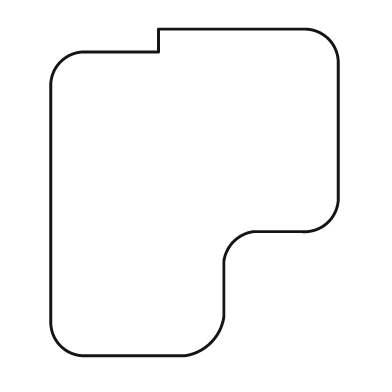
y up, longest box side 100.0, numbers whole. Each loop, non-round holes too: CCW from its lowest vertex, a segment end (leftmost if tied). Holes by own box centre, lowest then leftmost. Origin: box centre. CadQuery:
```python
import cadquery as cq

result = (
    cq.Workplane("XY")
    .moveTo(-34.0, -50.0)
    .lineTo(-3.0, -50.0)
    .threePointArc((5.0, -46.0), (9.0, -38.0))
    .lineTo(9.0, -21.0)
    .threePointArc((12.0, -15.0), (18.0, -12.0))
    .lineTo(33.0, -12.0)
    .threePointArc((41.0, -9.0), (44.0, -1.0))
    .lineTo(44.0, 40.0)
    .threePointArc((41.0, 47.0), (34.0, 50.0))
    .lineTo(-11.0, 50.0)
    .lineTo(-11.0, 43.0)
    .lineTo(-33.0, 43.0)
    .threePointArc((-41.0, 40.0), (-44.0, 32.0))
    .lineTo(-44.0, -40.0)
    .threePointArc((-41.0, -47.0), (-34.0, -50.0))
    .close()
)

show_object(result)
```